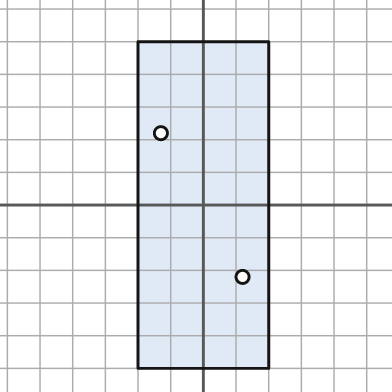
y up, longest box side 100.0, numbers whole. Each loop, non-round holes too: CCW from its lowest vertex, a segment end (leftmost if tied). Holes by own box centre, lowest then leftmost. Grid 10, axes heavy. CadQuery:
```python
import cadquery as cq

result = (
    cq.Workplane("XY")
    .moveTo(-20.0, -50.0)
    .lineTo(20.0, -50.0)
    .lineTo(20.0, 50.0)
    .lineTo(-20.0, 50.0)
    .close()
    .moveTo(12.0, -22.0)
    .circle(2.0)
    .moveTo(-13.0, 22.0)
    .circle(2.0)
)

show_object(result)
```